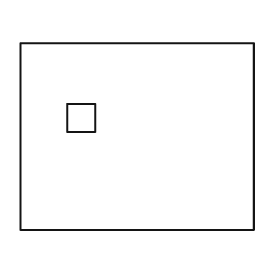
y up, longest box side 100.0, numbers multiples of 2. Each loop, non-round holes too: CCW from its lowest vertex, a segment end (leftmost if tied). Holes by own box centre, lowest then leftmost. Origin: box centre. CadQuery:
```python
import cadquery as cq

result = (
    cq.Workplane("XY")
    .moveTo(-50.0, -40.0)
    .lineTo(50.0, -40.0)
    .lineTo(50.0, 40.0)
    .lineTo(-50.0, 40.0)
    .close()
    .moveTo(-30.0, 2.0)
    .lineTo(-18.0, 2.0)
    .lineTo(-18.0, 14.0)
    .lineTo(-30.0, 14.0)
    .close()
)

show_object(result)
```